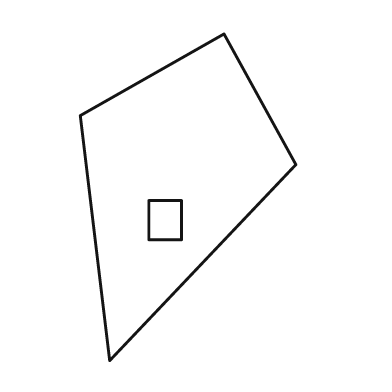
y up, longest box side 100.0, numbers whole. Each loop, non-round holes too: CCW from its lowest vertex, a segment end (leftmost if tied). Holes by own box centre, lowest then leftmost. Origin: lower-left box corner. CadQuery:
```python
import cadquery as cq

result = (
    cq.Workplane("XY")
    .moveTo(9.0, 0.0)
    .lineTo(66.0, 60.0)
    .lineTo(44.0, 100.0)
    .lineTo(0.0, 75.0)
    .close()
    .moveTo(21.0, 37.0)
    .lineTo(31.0, 37.0)
    .lineTo(31.0, 49.0)
    .lineTo(21.0, 49.0)
    .close()
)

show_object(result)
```